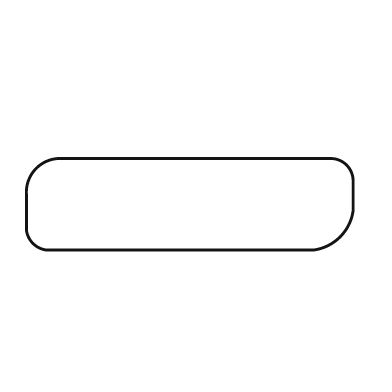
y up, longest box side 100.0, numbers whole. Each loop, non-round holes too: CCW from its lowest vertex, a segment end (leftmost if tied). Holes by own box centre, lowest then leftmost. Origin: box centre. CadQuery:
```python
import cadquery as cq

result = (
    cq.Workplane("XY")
    .moveTo(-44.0, -14.0)
    .lineTo(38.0, -14.0)
    .threePointArc((46.0, -10.0), (50.0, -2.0))
    .lineTo(50.0, 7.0)
    .threePointArc((48.0, 12.0), (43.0, 14.0))
    .lineTo(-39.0, 14.0)
    .threePointArc((-47.0, 11.0), (-50.0, 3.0))
    .lineTo(-50.0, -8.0)
    .threePointArc((-48.0, -12.0), (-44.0, -14.0))
    .close()
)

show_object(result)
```